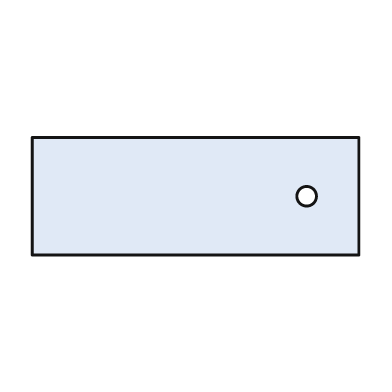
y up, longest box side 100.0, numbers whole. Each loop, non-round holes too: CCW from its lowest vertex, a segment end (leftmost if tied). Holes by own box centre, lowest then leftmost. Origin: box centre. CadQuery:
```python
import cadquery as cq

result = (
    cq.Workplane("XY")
    .moveTo(-50.0, -18.0)
    .lineTo(50.0, -18.0)
    .lineTo(50.0, 18.0)
    .lineTo(-50.0, 18.0)
    .close()
    .moveTo(34.0, 0.0)
    .circle(3.0)
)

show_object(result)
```